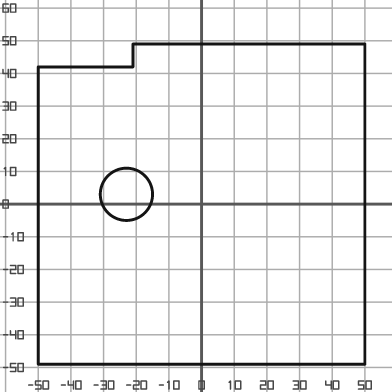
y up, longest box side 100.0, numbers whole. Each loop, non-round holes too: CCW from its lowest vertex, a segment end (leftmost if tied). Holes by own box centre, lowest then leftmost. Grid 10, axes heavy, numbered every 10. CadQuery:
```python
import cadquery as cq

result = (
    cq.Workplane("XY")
    .moveTo(-50.0, -49.0)
    .lineTo(50.0, -49.0)
    .lineTo(50.0, 49.0)
    .lineTo(-21.0, 49.0)
    .lineTo(-21.0, 42.0)
    .lineTo(-50.0, 42.0)
    .close()
    .moveTo(-23.0, 3.0)
    .circle(8.0)
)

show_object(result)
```